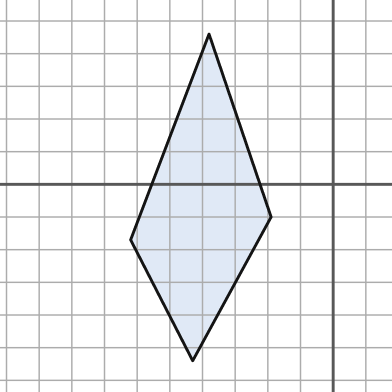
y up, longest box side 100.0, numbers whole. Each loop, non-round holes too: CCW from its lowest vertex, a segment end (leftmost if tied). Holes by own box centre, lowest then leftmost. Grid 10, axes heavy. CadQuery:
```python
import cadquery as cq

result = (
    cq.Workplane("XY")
    .moveTo(-43.0, -54.0)
    .lineTo(-19.0, -10.0)
    .lineTo(-38.0, 46.0)
    .lineTo(-62.0, -17.0)
    .close()
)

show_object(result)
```